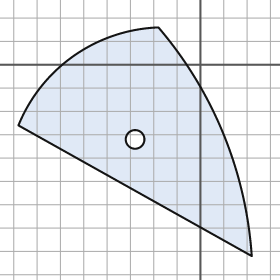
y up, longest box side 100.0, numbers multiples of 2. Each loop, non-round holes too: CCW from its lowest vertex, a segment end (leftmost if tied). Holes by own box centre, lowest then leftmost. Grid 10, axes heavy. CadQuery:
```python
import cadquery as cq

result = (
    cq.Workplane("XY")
    .moveTo(22.0, -82.0)
    .threePointArc((10.0, -30.0), (-18.0, 16.0))
    .threePointArc((-54.0, 4.0), (-78.0, -26.0))
    .close()
    .moveTo(-28.0, -32.0)
    .circle(4.0)
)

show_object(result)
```